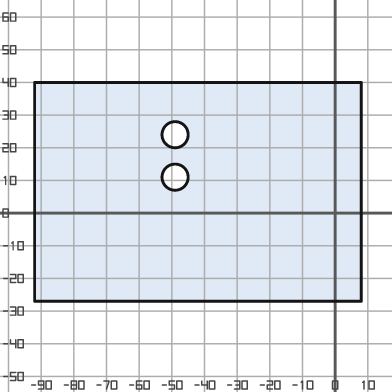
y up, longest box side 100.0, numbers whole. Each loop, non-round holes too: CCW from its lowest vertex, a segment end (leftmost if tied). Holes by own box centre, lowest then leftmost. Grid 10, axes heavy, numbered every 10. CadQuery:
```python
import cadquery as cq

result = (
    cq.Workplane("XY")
    .moveTo(-92.0, -27.0)
    .lineTo(8.0, -27.0)
    .lineTo(8.0, 40.0)
    .lineTo(-92.0, 40.0)
    .close()
    .moveTo(-49.0, 11.0)
    .circle(4.0)
    .moveTo(-49.0, 24.0)
    .circle(4.0)
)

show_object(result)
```